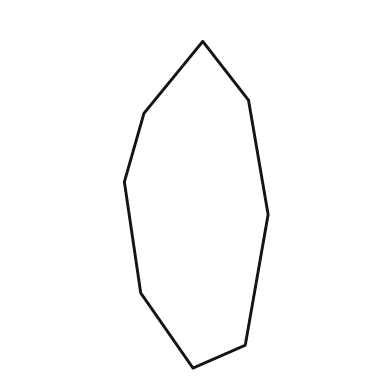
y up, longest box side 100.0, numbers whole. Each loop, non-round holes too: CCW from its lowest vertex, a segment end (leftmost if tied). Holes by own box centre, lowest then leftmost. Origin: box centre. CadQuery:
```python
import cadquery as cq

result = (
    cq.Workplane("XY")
    .moveTo(-1.0, -50.0)
    .lineTo(15.0, -43.0)
    .lineTo(22.0, -3.0)
    .lineTo(16.0, 32.0)
    .lineTo(2.0, 50.0)
    .lineTo(-16.0, 28.0)
    .lineTo(-22.0, 7.0)
    .lineTo(-17.0, -27.0)
    .close()
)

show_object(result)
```